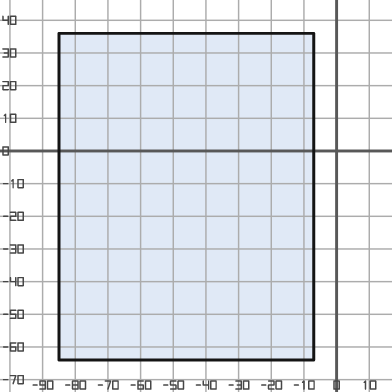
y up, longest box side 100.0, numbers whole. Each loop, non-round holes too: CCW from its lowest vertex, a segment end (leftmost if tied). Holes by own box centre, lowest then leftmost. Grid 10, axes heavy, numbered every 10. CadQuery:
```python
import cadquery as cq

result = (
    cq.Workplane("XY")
    .moveTo(-85.0, -64.0)
    .lineTo(-7.0, -64.0)
    .lineTo(-7.0, 36.0)
    .lineTo(-85.0, 36.0)
    .close()
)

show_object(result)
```